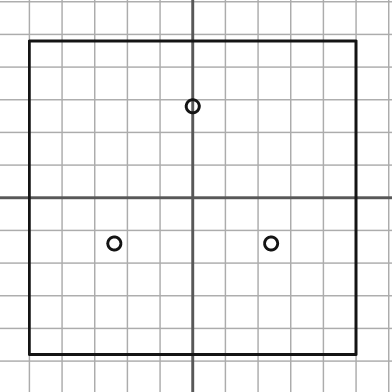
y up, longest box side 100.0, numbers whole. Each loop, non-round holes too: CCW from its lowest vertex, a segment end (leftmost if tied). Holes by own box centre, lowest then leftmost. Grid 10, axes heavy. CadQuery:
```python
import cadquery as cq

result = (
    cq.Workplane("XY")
    .moveTo(-50.0, -48.0)
    .lineTo(50.0, -48.0)
    .lineTo(50.0, 48.0)
    .lineTo(-50.0, 48.0)
    .close()
    .moveTo(-24.0, -14.0)
    .circle(2.0)
    .moveTo(24.0, -14.0)
    .circle(2.0)
    .moveTo(0.0, 28.0)
    .circle(2.0)
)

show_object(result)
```